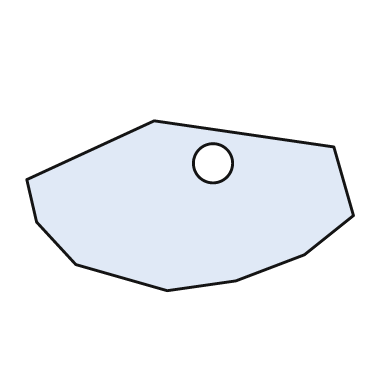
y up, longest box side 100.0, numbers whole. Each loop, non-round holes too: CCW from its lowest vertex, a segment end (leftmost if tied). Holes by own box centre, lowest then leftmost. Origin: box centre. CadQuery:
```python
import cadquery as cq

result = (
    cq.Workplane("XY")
    .moveTo(-7.0, -26.0)
    .lineTo(14.0, -23.0)
    .lineTo(35.0, -15.0)
    .lineTo(50.0, -3.0)
    .lineTo(44.0, 18.0)
    .lineTo(-11.0, 26.0)
    .lineTo(-50.0, 8.0)
    .lineTo(-47.0, -5.0)
    .lineTo(-35.0, -18.0)
    .close()
    .moveTo(7.0, 13.0)
    .circle(6.0)
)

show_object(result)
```